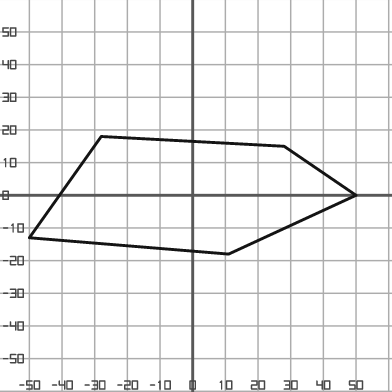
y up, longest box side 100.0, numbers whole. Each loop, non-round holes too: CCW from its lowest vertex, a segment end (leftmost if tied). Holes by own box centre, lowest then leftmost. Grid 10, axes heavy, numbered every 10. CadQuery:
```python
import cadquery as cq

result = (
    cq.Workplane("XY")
    .moveTo(11.0, -18.0)
    .lineTo(50.0, 0.0)
    .lineTo(28.0, 15.0)
    .lineTo(-28.0, 18.0)
    .lineTo(-50.0, -13.0)
    .close()
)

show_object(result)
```